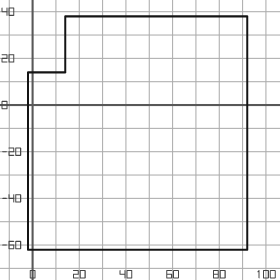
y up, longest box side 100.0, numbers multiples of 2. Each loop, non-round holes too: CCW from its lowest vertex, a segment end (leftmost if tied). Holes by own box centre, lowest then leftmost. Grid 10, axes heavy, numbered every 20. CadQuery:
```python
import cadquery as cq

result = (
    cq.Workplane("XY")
    .moveTo(-2.0, -62.0)
    .lineTo(92.0, -62.0)
    .lineTo(92.0, 38.0)
    .lineTo(14.0, 38.0)
    .lineTo(14.0, 14.0)
    .lineTo(-2.0, 14.0)
    .close()
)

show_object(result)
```